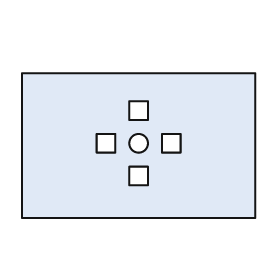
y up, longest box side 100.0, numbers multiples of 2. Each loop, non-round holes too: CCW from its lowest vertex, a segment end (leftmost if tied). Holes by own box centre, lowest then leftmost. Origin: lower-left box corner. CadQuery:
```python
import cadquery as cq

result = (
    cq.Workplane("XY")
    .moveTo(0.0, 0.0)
    .lineTo(100.0, 0.0)
    .lineTo(100.0, 62.0)
    .lineTo(0.0, 62.0)
    .close()
    .moveTo(46.0, 14.0)
    .lineTo(54.0, 14.0)
    .lineTo(54.0, 22.0)
    .lineTo(46.0, 22.0)
    .close()
    .moveTo(32.0, 28.0)
    .lineTo(40.0, 28.0)
    .lineTo(40.0, 36.0)
    .lineTo(32.0, 36.0)
    .close()
    .moveTo(50.0, 32.0)
    .circle(4.0)
    .moveTo(60.0, 28.0)
    .lineTo(68.0, 28.0)
    .lineTo(68.0, 36.0)
    .lineTo(60.0, 36.0)
    .close()
    .moveTo(46.0, 42.0)
    .lineTo(54.0, 42.0)
    .lineTo(54.0, 50.0)
    .lineTo(46.0, 50.0)
    .close()
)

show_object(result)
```